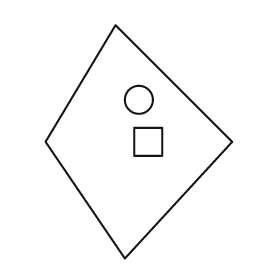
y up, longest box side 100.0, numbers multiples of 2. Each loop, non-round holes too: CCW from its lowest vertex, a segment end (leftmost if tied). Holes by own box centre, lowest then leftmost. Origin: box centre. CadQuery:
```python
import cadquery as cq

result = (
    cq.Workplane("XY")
    .moveTo(-6.0, -50.0)
    .lineTo(40.0, 0.0)
    .lineTo(-10.0, 50.0)
    .lineTo(-40.0, 0.0)
    .close()
    .moveTo(-2.0, -6.0)
    .lineTo(10.0, -6.0)
    .lineTo(10.0, 6.0)
    .lineTo(-2.0, 6.0)
    .close()
    .moveTo(0.0, 18.0)
    .circle(6.0)
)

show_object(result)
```